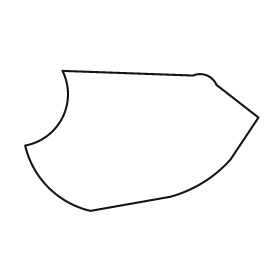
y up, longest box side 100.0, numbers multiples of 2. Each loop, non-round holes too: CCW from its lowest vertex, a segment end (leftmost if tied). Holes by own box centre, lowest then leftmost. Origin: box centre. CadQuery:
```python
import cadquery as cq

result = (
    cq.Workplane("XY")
    .moveTo(-22.0, -30.0)
    .lineTo(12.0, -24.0)
    .threePointArc((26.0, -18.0), (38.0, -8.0))
    .lineTo(50.0, 10.0)
    .lineTo(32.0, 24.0)
    .threePointArc((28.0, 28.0), (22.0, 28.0))
    .lineTo(-34.0, 30.0)
    .threePointArc((-34.0, 10.0), (-50.0, -2.0))
    .threePointArc((-40.0, -20.0), (-22.0, -30.0))
    .close()
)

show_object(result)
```